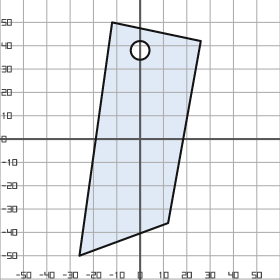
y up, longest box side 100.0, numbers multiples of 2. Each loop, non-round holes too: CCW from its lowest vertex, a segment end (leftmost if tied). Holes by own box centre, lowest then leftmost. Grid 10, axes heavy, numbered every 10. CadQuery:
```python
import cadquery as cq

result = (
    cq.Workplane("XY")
    .moveTo(-26.0, -50.0)
    .lineTo(12.0, -36.0)
    .lineTo(26.0, 42.0)
    .lineTo(-12.0, 50.0)
    .close()
    .moveTo(0.0, 38.0)
    .circle(4.0)
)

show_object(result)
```